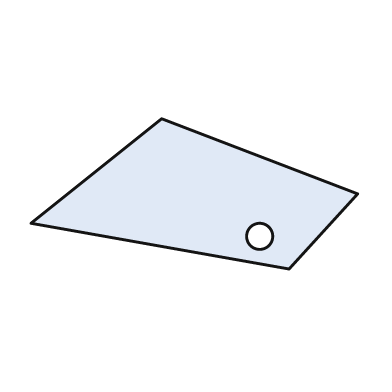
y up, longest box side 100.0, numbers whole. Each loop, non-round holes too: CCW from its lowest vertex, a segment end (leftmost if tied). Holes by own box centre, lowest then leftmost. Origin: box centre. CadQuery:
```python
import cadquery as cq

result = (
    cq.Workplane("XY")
    .moveTo(29.0, -23.0)
    .lineTo(50.0, 0.0)
    .lineTo(-10.0, 23.0)
    .lineTo(-50.0, -9.0)
    .close()
    .moveTo(20.0, -13.0)
    .circle(4.0)
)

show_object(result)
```